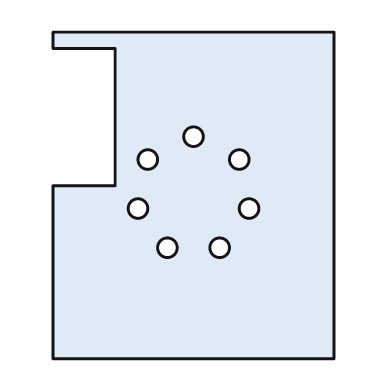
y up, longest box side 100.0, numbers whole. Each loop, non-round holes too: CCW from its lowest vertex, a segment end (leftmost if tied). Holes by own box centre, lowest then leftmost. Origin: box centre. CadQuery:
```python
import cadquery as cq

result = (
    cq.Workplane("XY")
    .moveTo(-43.0, -50.0)
    .lineTo(43.0, -50.0)
    .lineTo(43.0, 50.0)
    .lineTo(-43.0, 50.0)
    .lineTo(-43.0, 45.0)
    .lineTo(-24.0, 45.0)
    .lineTo(-24.0, 3.0)
    .lineTo(-43.0, 3.0)
    .close()
    .moveTo(-8.0, -16.0)
    .circle(3.0)
    .moveTo(8.0, -16.0)
    .circle(3.0)
    .moveTo(-17.0, -4.0)
    .circle(3.0)
    .moveTo(17.0, -4.0)
    .circle(3.0)
    .moveTo(-14.0, 11.0)
    .circle(3.0)
    .moveTo(14.0, 11.0)
    .circle(3.0)
    .moveTo(0.0, 18.0)
    .circle(3.0)
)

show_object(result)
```